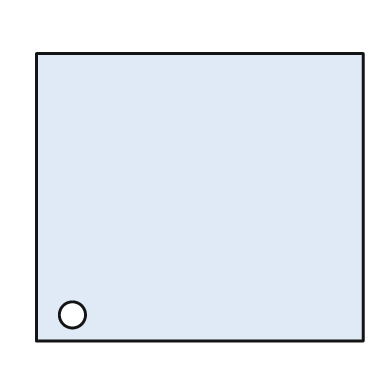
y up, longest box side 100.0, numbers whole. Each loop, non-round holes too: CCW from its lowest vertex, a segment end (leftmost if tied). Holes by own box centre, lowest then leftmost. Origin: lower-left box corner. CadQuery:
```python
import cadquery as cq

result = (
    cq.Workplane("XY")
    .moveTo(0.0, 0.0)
    .lineTo(100.0, 0.0)
    .lineTo(100.0, 88.0)
    .lineTo(0.0, 88.0)
    .close()
    .moveTo(11.0, 8.0)
    .circle(4.0)
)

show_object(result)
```